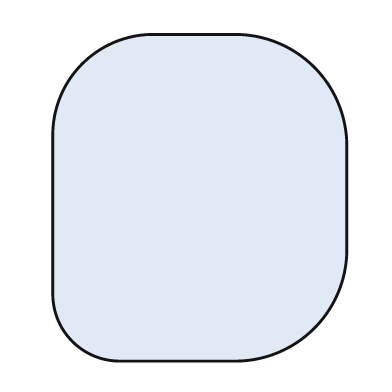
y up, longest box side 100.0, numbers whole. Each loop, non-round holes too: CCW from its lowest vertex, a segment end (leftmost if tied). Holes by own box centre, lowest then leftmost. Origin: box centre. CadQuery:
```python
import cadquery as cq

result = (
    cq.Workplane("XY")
    .moveTo(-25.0, -50.0)
    .lineTo(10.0, -50.0)
    .threePointArc((35.0, -40.0), (45.0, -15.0))
    .lineTo(45.0, 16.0)
    .threePointArc((35.0, 40.0), (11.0, 50.0))
    .lineTo(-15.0, 50.0)
    .threePointArc((-36.0, 41.0), (-45.0, 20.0))
    .lineTo(-45.0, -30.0)
    .threePointArc((-39.0, -44.0), (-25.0, -50.0))
    .close()
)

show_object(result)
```